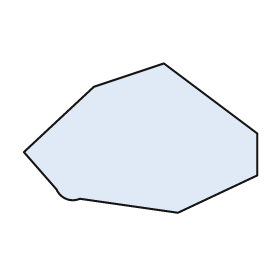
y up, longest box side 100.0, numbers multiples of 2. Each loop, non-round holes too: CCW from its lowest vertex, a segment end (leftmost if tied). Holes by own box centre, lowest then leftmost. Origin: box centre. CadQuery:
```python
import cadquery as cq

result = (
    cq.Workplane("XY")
    .moveTo(16.0, -32.0)
    .lineTo(50.0, -16.0)
    .lineTo(50.0, 2.0)
    .lineTo(10.0, 32.0)
    .lineTo(-20.0, 22.0)
    .lineTo(-50.0, -6.0)
    .lineTo(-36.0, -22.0)
    .threePointArc((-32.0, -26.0), (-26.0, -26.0))
    .close()
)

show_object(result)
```